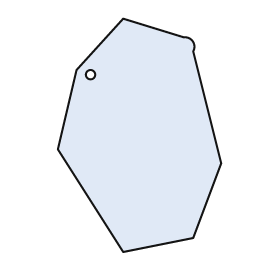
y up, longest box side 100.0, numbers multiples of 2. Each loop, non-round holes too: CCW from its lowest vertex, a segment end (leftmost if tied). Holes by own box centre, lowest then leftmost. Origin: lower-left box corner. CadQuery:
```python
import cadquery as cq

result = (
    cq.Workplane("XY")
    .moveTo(28.0, 0.0)
    .lineTo(58.0, 6.0)
    .lineTo(70.0, 38.0)
    .lineTo(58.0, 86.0)
    .threePointArc((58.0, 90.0), (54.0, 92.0))
    .lineTo(28.0, 100.0)
    .lineTo(8.0, 78.0)
    .lineTo(0.0, 44.0)
    .close()
    .moveTo(14.0, 76.0)
    .circle(2.0)
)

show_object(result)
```